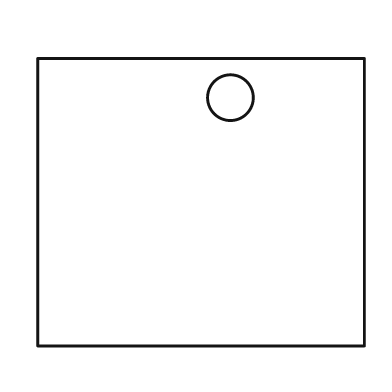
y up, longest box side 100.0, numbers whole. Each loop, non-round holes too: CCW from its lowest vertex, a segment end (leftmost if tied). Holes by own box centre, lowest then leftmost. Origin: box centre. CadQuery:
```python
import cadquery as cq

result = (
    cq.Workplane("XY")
    .moveTo(-50.0, -44.0)
    .lineTo(50.0, -44.0)
    .lineTo(50.0, 44.0)
    .lineTo(-50.0, 44.0)
    .close()
    .moveTo(9.0, 32.0)
    .circle(7.0)
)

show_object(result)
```